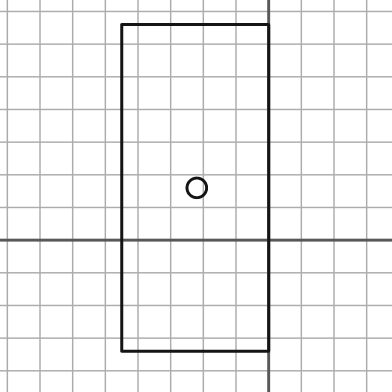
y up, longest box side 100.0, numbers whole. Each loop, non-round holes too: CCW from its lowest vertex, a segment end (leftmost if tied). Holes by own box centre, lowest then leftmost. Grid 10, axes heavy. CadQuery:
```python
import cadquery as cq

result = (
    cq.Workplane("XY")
    .moveTo(-45.0, -34.0)
    .lineTo(0.0, -34.0)
    .lineTo(0.0, 66.0)
    .lineTo(-45.0, 66.0)
    .close()
    .moveTo(-22.0, 16.0)
    .circle(3.0)
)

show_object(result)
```